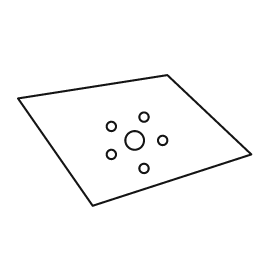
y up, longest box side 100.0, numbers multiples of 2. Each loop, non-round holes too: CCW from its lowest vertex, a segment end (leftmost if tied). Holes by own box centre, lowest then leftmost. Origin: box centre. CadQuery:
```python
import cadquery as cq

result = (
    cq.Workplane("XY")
    .moveTo(-18.0, -28.0)
    .lineTo(50.0, -6.0)
    .lineTo(14.0, 28.0)
    .lineTo(-50.0, 18.0)
    .close()
    .moveTo(4.0, -12.0)
    .circle(2.0)
    .moveTo(-10.0, -6.0)
    .circle(2.0)
    .moveTo(0.0, 0.0)
    .circle(4.0)
    .moveTo(12.0, 0.0)
    .circle(2.0)
    .moveTo(-10.0, 6.0)
    .circle(2.0)
    .moveTo(4.0, 10.0)
    .circle(2.0)
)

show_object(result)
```